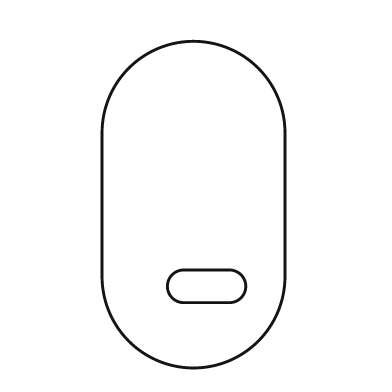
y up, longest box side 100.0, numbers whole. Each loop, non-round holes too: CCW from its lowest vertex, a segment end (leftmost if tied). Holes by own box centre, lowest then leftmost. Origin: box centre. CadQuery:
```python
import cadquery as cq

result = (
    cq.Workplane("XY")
    .moveTo(-28.0, -22.0)
    .threePointArc((0.0, -50.0), (28.0, -22.0))
    .lineTo(28.0, 22.0)
    .threePointArc((0.0, 50.0), (-28.0, 22.0))
    .close()
    .moveTo(-3.0, -30.0)
    .lineTo(11.0, -30.0)
    .threePointArc((16.0, -25.0), (11.0, -20.0))
    .lineTo(-3.0, -20.0)
    .threePointArc((-8.0, -25.0), (-3.0, -30.0))
    .close()
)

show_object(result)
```